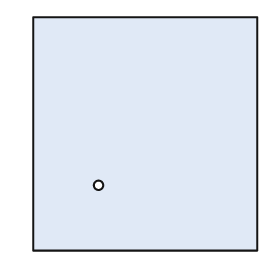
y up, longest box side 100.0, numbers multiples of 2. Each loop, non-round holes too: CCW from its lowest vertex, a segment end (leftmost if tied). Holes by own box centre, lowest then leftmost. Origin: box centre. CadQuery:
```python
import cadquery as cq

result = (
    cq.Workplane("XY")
    .moveTo(-48.0, -50.0)
    .lineTo(48.0, -50.0)
    .lineTo(48.0, 50.0)
    .lineTo(-48.0, 50.0)
    .close()
    .moveTo(-20.0, -22.0)
    .circle(2.0)
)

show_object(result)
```